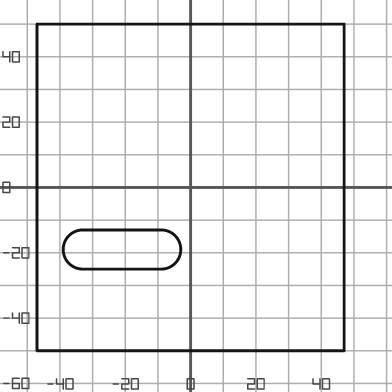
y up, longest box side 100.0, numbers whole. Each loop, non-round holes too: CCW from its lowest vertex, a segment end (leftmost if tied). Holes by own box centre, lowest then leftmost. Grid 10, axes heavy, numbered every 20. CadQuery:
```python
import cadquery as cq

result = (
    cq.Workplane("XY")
    .moveTo(-47.0, -50.0)
    .lineTo(47.0, -50.0)
    .lineTo(47.0, 50.0)
    .lineTo(-47.0, 50.0)
    .close()
    .moveTo(-33.0, -25.0)
    .lineTo(-9.0, -25.0)
    .threePointArc((-3.0, -19.0), (-9.0, -13.0))
    .lineTo(-33.0, -13.0)
    .threePointArc((-39.0, -19.0), (-33.0, -25.0))
    .close()
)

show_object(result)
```